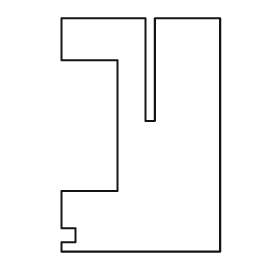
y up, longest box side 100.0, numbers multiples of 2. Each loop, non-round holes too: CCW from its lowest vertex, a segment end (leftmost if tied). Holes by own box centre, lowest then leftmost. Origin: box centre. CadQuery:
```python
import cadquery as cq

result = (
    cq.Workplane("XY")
    .moveTo(-34.0, -50.0)
    .lineTo(34.0, -50.0)
    .lineTo(34.0, 50.0)
    .lineTo(6.0, 50.0)
    .lineTo(6.0, 6.0)
    .lineTo(2.0, 6.0)
    .lineTo(2.0, 50.0)
    .lineTo(-34.0, 50.0)
    .lineTo(-34.0, 32.0)
    .lineTo(-10.0, 32.0)
    .lineTo(-10.0, -24.0)
    .lineTo(-34.0, -24.0)
    .lineTo(-34.0, -40.0)
    .lineTo(-28.0, -40.0)
    .lineTo(-28.0, -46.0)
    .lineTo(-34.0, -46.0)
    .close()
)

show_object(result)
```